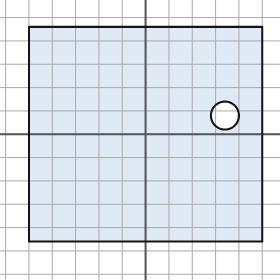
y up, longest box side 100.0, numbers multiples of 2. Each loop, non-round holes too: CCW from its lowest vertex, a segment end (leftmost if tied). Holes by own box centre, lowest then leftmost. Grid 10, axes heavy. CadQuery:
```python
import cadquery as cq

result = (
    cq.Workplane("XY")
    .moveTo(-50.0, -46.0)
    .lineTo(50.0, -46.0)
    .lineTo(50.0, 46.0)
    .lineTo(-50.0, 46.0)
    .close()
    .moveTo(34.0, 8.0)
    .circle(6.0)
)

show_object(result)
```